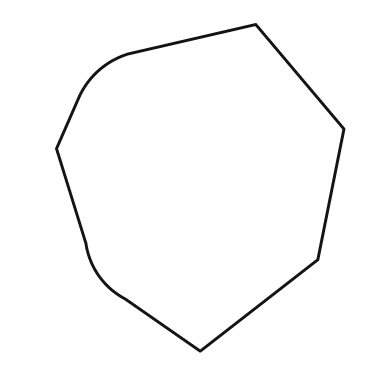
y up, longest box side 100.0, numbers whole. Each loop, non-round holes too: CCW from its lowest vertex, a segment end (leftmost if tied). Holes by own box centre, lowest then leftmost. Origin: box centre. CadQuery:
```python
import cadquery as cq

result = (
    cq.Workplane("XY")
    .moveTo(0.0, -50.0)
    .lineTo(36.0, -22.0)
    .lineTo(44.0, 18.0)
    .lineTo(17.0, 50.0)
    .lineTo(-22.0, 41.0)
    .threePointArc((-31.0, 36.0), (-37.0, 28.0))
    .lineTo(-44.0, 12.0)
    .lineTo(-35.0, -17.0)
    .threePointArc((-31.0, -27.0), (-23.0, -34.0))
    .close()
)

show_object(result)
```